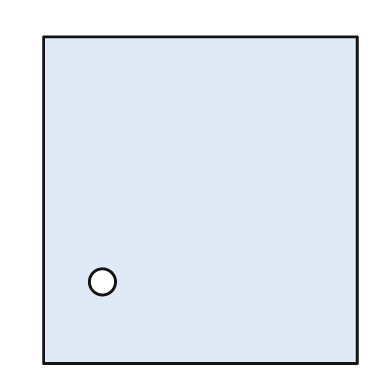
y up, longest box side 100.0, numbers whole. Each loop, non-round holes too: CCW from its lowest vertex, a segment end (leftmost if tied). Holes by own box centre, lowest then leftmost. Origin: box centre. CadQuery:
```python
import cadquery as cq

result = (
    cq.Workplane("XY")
    .moveTo(-48.0, -50.0)
    .lineTo(48.0, -50.0)
    .lineTo(48.0, 50.0)
    .lineTo(-48.0, 50.0)
    .close()
    .moveTo(-30.0, -25.0)
    .circle(4.0)
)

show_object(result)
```